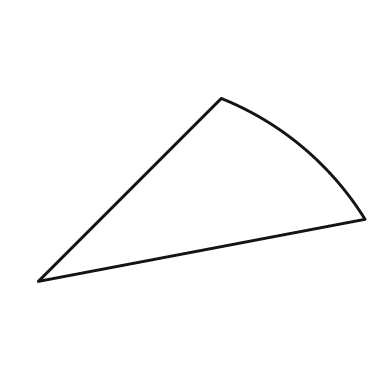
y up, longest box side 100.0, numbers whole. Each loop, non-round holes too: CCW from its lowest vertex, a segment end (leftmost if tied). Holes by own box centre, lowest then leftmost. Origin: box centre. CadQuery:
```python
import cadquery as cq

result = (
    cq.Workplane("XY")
    .moveTo(-50.0, -28.0)
    .lineTo(50.0, -9.0)
    .threePointArc((31.0, 13.0), (6.0, 28.0))
    .close()
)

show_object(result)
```